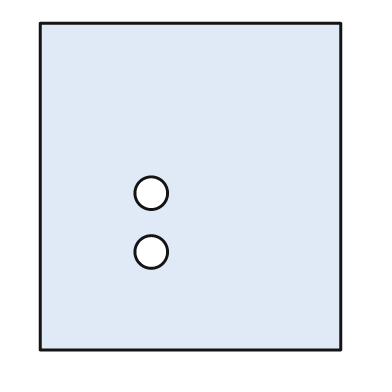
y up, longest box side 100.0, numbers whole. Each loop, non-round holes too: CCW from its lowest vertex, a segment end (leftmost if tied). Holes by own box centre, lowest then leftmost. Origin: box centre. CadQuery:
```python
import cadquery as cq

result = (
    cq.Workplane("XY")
    .moveTo(-46.0, -50.0)
    .lineTo(46.0, -50.0)
    .lineTo(46.0, 50.0)
    .lineTo(-46.0, 50.0)
    .close()
    .moveTo(-12.0, -20.0)
    .circle(5.0)
    .moveTo(-12.0, -2.0)
    .circle(5.0)
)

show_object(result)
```